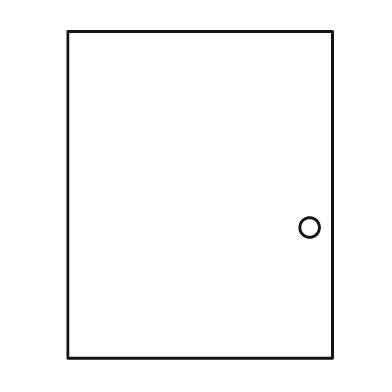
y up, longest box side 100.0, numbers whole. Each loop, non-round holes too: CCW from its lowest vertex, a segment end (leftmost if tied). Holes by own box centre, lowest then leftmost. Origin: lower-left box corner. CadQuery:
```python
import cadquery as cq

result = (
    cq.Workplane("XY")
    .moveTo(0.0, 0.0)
    .lineTo(81.0, 0.0)
    .lineTo(81.0, 100.0)
    .lineTo(0.0, 100.0)
    .close()
    .moveTo(74.0, 40.0)
    .circle(3.0)
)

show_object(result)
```